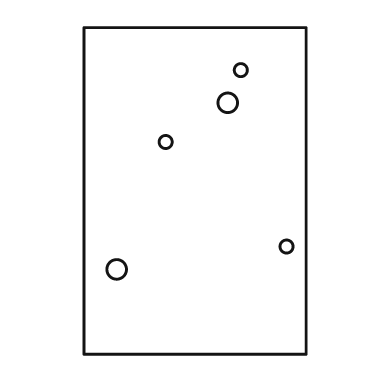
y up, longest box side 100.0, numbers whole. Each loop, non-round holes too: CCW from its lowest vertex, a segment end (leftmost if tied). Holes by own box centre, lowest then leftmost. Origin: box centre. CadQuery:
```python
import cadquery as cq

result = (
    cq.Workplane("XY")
    .moveTo(-34.0, -50.0)
    .lineTo(34.0, -50.0)
    .lineTo(34.0, 50.0)
    .lineTo(-34.0, 50.0)
    .close()
    .moveTo(-24.0, -24.0)
    .circle(3.0)
    .moveTo(28.0, -17.0)
    .circle(2.0)
    .moveTo(-9.0, 15.0)
    .circle(2.0)
    .moveTo(10.0, 27.0)
    .circle(3.0)
    .moveTo(14.0, 37.0)
    .circle(2.0)
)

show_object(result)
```